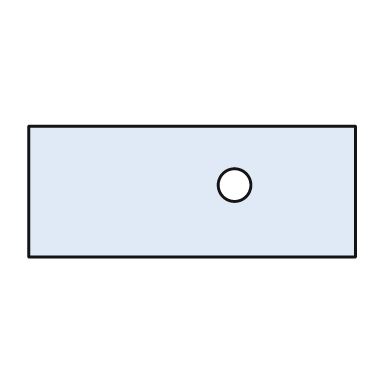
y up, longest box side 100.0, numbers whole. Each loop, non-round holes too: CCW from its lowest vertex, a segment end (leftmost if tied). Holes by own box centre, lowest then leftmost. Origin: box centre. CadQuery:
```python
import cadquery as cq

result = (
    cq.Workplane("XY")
    .moveTo(-50.0, -20.0)
    .lineTo(50.0, -20.0)
    .lineTo(50.0, 20.0)
    .lineTo(-50.0, 20.0)
    .close()
    .moveTo(13.0, 2.0)
    .circle(5.0)
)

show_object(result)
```